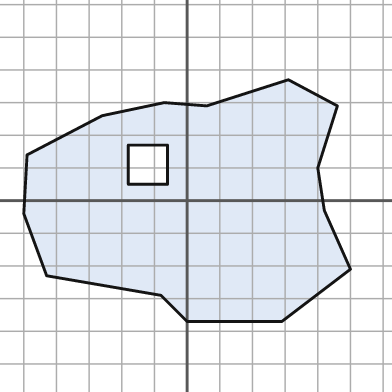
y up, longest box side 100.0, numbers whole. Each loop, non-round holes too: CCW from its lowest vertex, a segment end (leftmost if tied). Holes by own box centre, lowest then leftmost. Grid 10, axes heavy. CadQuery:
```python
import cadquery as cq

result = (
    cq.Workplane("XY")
    .moveTo(0.0, -37.0)
    .lineTo(29.0, -37.0)
    .lineTo(50.0, -21.0)
    .lineTo(42.0, -3.0)
    .lineTo(40.0, 10.0)
    .lineTo(46.0, 29.0)
    .lineTo(31.0, 37.0)
    .lineTo(6.0, 29.0)
    .lineTo(-7.0, 30.0)
    .lineTo(-26.0, 26.0)
    .lineTo(-49.0, 14.0)
    .lineTo(-50.0, -4.0)
    .lineTo(-43.0, -23.0)
    .lineTo(-8.0, -29.0)
    .close()
    .moveTo(-18.0, 5.0)
    .lineTo(-6.0, 5.0)
    .lineTo(-6.0, 17.0)
    .lineTo(-18.0, 17.0)
    .close()
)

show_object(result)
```